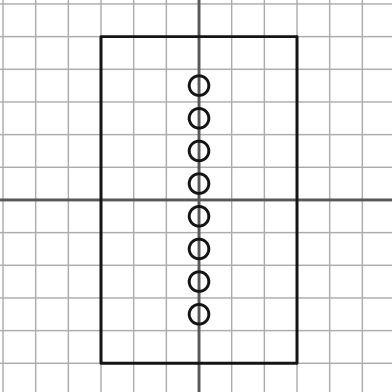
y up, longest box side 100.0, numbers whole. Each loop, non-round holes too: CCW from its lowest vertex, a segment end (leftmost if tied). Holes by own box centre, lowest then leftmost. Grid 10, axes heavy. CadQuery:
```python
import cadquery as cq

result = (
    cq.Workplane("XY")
    .moveTo(-30.0, -50.0)
    .lineTo(30.0, -50.0)
    .lineTo(30.0, 50.0)
    .lineTo(-30.0, 50.0)
    .close()
    .moveTo(0.0, -35.0)
    .circle(3.0)
    .moveTo(0.0, -25.0)
    .circle(3.0)
    .moveTo(0.0, -15.0)
    .circle(3.0)
    .moveTo(0.0, -5.0)
    .circle(3.0)
    .moveTo(0.0, 5.0)
    .circle(3.0)
    .moveTo(0.0, 15.0)
    .circle(3.0)
    .moveTo(0.0, 25.0)
    .circle(3.0)
    .moveTo(0.0, 35.0)
    .circle(3.0)
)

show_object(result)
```